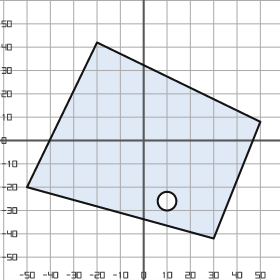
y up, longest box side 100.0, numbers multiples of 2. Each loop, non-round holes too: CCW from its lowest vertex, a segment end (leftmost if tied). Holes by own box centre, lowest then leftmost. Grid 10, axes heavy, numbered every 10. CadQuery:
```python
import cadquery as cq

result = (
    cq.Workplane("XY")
    .moveTo(30.0, -42.0)
    .lineTo(50.0, 8.0)
    .lineTo(-20.0, 42.0)
    .lineTo(-50.0, -20.0)
    .close()
    .moveTo(10.0, -26.0)
    .circle(4.0)
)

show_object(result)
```